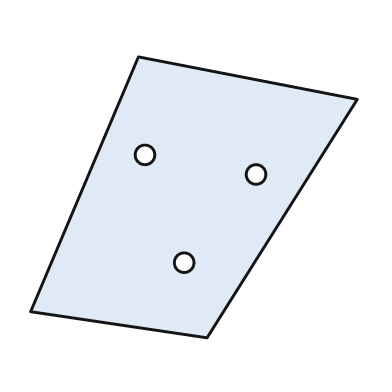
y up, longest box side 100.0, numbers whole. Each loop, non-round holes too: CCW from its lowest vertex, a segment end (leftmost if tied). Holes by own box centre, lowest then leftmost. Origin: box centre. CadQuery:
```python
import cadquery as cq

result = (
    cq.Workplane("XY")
    .moveTo(4.0, -43.0)
    .lineTo(50.0, 30.0)
    .lineTo(-17.0, 43.0)
    .lineTo(-50.0, -35.0)
    .close()
    .moveTo(-3.0, -20.0)
    .circle(3.0)
    .moveTo(19.0, 7.0)
    .circle(3.0)
    .moveTo(-15.0, 13.0)
    .circle(3.0)
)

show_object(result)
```